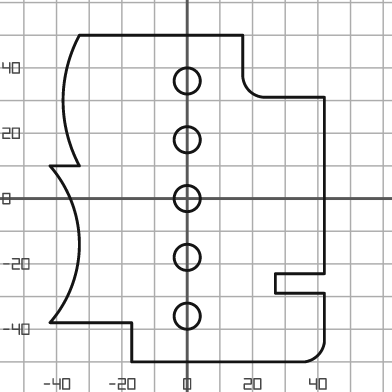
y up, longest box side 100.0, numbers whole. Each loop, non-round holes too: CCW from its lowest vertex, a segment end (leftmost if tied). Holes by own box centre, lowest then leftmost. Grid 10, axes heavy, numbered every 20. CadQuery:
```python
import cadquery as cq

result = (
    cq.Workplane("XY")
    .moveTo(-17.0, -50.0)
    .lineTo(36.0, -50.0)
    .threePointArc((40.0, -48.0), (42.0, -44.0))
    .lineTo(42.0, -29.0)
    .lineTo(27.0, -29.0)
    .lineTo(27.0, -23.0)
    .lineTo(42.0, -23.0)
    .lineTo(42.0, 31.0)
    .lineTo(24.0, 31.0)
    .threePointArc((19.0, 33.0), (17.0, 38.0))
    .lineTo(17.0, 50.0)
    .lineTo(-33.0, 50.0)
    .threePointArc((-38.0, 30.0), (-33.0, 10.0))
    .lineTo(-42.0, 10.0)
    .threePointArc((-33.0, -14.0), (-42.0, -38.0))
    .lineTo(-17.0, -38.0)
    .close()
    .moveTo(0.0, -36.0)
    .circle(4.0)
    .moveTo(0.0, -18.0)
    .circle(4.0)
    .moveTo(0.0, 0.0)
    .circle(4.0)
    .moveTo(0.0, 18.0)
    .circle(4.0)
    .moveTo(0.0, 36.0)
    .circle(4.0)
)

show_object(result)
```